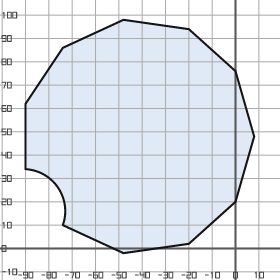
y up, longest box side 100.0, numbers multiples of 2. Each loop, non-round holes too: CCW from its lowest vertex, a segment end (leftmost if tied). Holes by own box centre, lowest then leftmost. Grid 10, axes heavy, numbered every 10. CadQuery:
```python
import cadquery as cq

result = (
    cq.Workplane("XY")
    .moveTo(-48.0, -2.0)
    .lineTo(-20.0, 2.0)
    .lineTo(0.0, 20.0)
    .lineTo(8.0, 48.0)
    .lineTo(0.0, 76.0)
    .lineTo(-20.0, 94.0)
    .lineTo(-48.0, 98.0)
    .lineTo(-74.0, 86.0)
    .lineTo(-90.0, 62.0)
    .lineTo(-90.0, 34.0)
    .threePointArc((-76.0, 26.0), (-74.0, 10.0))
    .close()
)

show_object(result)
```